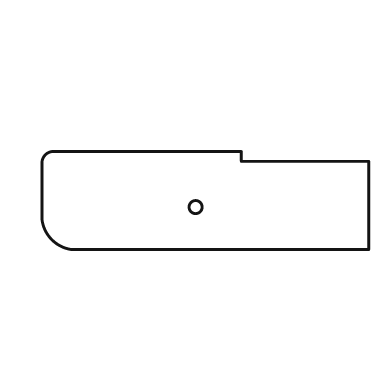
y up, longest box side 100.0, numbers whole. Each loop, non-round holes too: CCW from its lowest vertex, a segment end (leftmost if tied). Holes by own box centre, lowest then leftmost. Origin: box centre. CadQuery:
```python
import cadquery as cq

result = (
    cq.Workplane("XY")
    .moveTo(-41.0, -15.0)
    .lineTo(50.0, -15.0)
    .lineTo(50.0, 12.0)
    .lineTo(11.0, 12.0)
    .lineTo(11.0, 15.0)
    .lineTo(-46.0, 15.0)
    .threePointArc((-49.0, 14.0), (-50.0, 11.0))
    .lineTo(-50.0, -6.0)
    .threePointArc((-47.0, -12.0), (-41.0, -15.0))
    .close()
    .moveTo(-3.0, -2.0)
    .circle(2.0)
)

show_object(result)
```